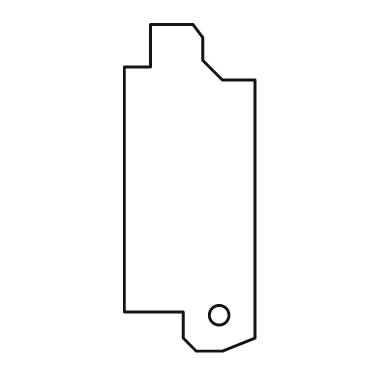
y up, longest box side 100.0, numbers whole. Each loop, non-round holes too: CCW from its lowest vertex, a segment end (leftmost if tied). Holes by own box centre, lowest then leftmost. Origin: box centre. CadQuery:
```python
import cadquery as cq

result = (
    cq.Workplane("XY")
    .moveTo(2.0, -50.0)
    .lineTo(10.0, -50.0)
    .lineTo(20.0, -46.0)
    .lineTo(20.0, 33.0)
    .lineTo(10.0, 33.0)
    .lineTo(4.0, 39.0)
    .lineTo(4.0, 46.0)
    .lineTo(1.0, 50.0)
    .lineTo(-12.0, 50.0)
    .lineTo(-12.0, 37.0)
    .lineTo(-20.0, 37.0)
    .lineTo(-20.0, -38.0)
    .lineTo(-2.0, -38.0)
    .lineTo(-2.0, -46.0)
    .close()
    .moveTo(9.0, -39.0)
    .circle(3.0)
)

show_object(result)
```